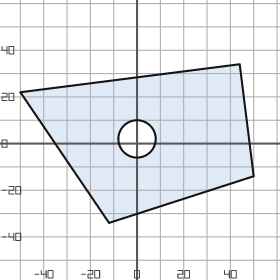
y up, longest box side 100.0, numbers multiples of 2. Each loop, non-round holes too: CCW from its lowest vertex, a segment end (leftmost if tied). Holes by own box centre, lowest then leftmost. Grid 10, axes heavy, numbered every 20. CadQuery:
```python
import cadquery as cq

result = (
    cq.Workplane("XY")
    .moveTo(-12.0, -34.0)
    .lineTo(50.0, -14.0)
    .lineTo(44.0, 34.0)
    .lineTo(-50.0, 22.0)
    .close()
    .moveTo(0.0, 2.0)
    .circle(8.0)
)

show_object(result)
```